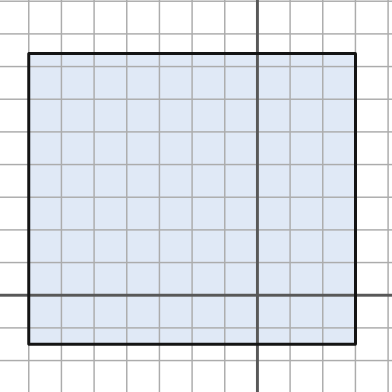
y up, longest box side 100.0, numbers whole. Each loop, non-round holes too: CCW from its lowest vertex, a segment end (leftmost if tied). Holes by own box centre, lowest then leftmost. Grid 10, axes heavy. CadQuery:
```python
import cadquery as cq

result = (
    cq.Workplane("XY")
    .moveTo(-70.0, -15.0)
    .lineTo(30.0, -15.0)
    .lineTo(30.0, 74.0)
    .lineTo(-70.0, 74.0)
    .close()
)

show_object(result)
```